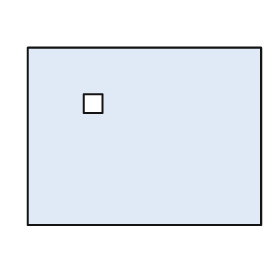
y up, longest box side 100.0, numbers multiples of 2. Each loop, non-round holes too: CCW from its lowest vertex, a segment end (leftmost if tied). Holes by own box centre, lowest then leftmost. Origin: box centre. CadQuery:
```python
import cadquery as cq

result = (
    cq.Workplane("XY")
    .moveTo(-50.0, -38.0)
    .lineTo(50.0, -38.0)
    .lineTo(50.0, 38.0)
    .lineTo(-50.0, 38.0)
    .close()
    .moveTo(-26.0, 10.0)
    .lineTo(-18.0, 10.0)
    .lineTo(-18.0, 18.0)
    .lineTo(-26.0, 18.0)
    .close()
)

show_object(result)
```